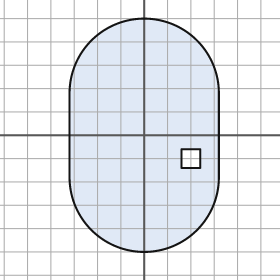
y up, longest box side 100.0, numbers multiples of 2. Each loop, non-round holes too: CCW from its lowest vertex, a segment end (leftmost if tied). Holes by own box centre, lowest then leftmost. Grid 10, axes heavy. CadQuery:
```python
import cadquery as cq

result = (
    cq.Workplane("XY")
    .moveTo(-32.0, -18.0)
    .threePointArc((0.0, -50.0), (32.0, -18.0))
    .lineTo(32.0, 18.0)
    .threePointArc((0.0, 50.0), (-32.0, 18.0))
    .close()
    .moveTo(16.0, -14.0)
    .lineTo(24.0, -14.0)
    .lineTo(24.0, -6.0)
    .lineTo(16.0, -6.0)
    .close()
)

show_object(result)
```